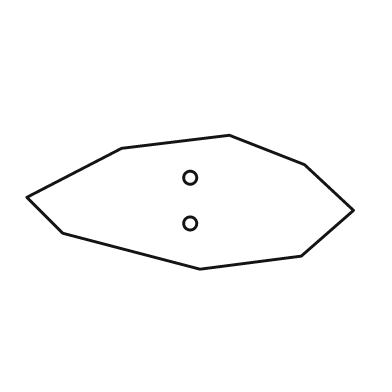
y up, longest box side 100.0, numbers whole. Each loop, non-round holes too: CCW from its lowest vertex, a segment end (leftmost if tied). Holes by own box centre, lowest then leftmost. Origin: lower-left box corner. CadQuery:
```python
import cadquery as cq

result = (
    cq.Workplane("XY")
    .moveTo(53.0, 0.0)
    .lineTo(84.0, 4.0)
    .lineTo(100.0, 18.0)
    .lineTo(85.0, 32.0)
    .lineTo(62.0, 41.0)
    .lineTo(29.0, 37.0)
    .lineTo(0.0, 22.0)
    .lineTo(11.0, 11.0)
    .close()
    .moveTo(50.0, 14.0)
    .circle(2.0)
    .moveTo(50.0, 28.0)
    .circle(2.0)
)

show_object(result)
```